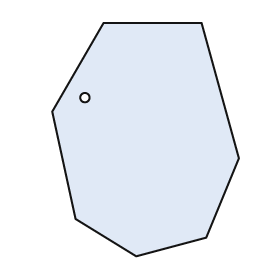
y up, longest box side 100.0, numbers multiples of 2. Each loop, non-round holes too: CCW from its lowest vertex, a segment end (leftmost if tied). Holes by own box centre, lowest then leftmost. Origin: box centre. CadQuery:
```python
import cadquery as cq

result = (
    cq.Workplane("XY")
    .moveTo(-4.0, -50.0)
    .lineTo(26.0, -42.0)
    .lineTo(40.0, -8.0)
    .lineTo(24.0, 50.0)
    .lineTo(-18.0, 50.0)
    .lineTo(-40.0, 12.0)
    .lineTo(-30.0, -34.0)
    .close()
    .moveTo(-26.0, 18.0)
    .circle(2.0)
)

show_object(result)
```